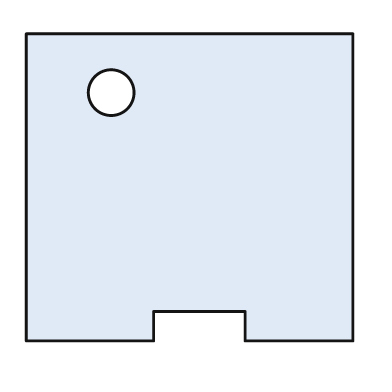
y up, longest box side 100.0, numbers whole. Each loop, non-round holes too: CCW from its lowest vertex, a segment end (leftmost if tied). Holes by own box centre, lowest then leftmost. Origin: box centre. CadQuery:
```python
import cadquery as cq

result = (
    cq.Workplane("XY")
    .moveTo(-50.0, -47.0)
    .lineTo(-11.0, -47.0)
    .lineTo(-11.0, -38.0)
    .lineTo(17.0, -38.0)
    .lineTo(17.0, -47.0)
    .lineTo(50.0, -47.0)
    .lineTo(50.0, 47.0)
    .lineTo(-50.0, 47.0)
    .close()
    .moveTo(-24.0, 29.0)
    .circle(7.0)
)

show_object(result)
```